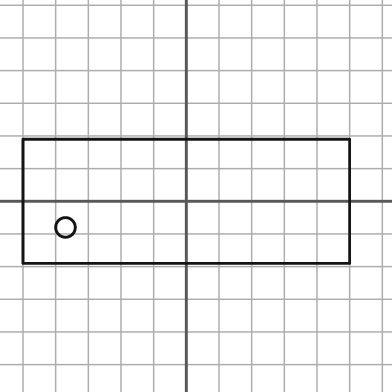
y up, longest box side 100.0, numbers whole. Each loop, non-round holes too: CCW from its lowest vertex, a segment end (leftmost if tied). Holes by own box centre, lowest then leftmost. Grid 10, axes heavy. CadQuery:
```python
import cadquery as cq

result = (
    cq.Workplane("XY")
    .moveTo(-50.0, -19.0)
    .lineTo(50.0, -19.0)
    .lineTo(50.0, 19.0)
    .lineTo(-50.0, 19.0)
    .close()
    .moveTo(-37.0, -8.0)
    .circle(3.0)
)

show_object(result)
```